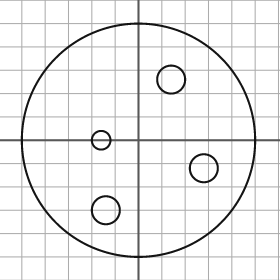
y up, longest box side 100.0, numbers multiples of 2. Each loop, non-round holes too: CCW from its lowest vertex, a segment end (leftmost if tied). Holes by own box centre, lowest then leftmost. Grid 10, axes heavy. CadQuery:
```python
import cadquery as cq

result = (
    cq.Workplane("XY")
    .moveTo(0.0, 0.0)
    .circle(50.0)
    .moveTo(-14.0, -30.0)
    .circle(6.0)
    .moveTo(28.0, -12.0)
    .circle(6.0)
    .moveTo(-16.0, 0.0)
    .circle(4.0)
    .moveTo(14.0, 26.0)
    .circle(6.0)
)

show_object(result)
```